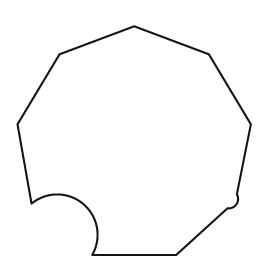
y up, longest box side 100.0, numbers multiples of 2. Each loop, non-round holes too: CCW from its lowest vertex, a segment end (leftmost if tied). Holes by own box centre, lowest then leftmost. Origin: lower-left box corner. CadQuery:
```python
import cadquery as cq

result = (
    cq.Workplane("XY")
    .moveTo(32.0, 0.0)
    .lineTo(68.0, 0.0)
    .lineTo(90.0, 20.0)
    .threePointArc((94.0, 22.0), (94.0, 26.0))
    .lineTo(100.0, 56.0)
    .lineTo(82.0, 86.0)
    .lineTo(50.0, 98.0)
    .lineTo(18.0, 86.0)
    .lineTo(0.0, 56.0)
    .lineTo(6.0, 22.0)
    .threePointArc((28.0, 22.0), (32.0, 0.0))
    .close()
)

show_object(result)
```